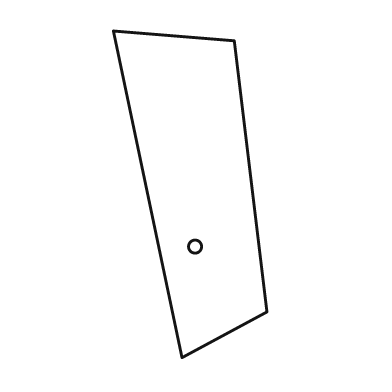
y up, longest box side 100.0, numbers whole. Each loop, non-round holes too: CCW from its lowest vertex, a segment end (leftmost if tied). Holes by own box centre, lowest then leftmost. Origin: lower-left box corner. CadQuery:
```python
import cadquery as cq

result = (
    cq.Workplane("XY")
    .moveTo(21.0, 0.0)
    .lineTo(47.0, 14.0)
    .lineTo(37.0, 97.0)
    .lineTo(0.0, 100.0)
    .close()
    .moveTo(25.0, 34.0)
    .circle(2.0)
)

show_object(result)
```